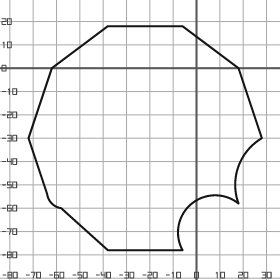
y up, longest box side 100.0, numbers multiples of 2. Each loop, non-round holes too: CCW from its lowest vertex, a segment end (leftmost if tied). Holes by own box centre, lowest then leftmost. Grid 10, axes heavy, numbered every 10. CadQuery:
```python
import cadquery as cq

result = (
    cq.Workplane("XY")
    .moveTo(-38.0, -78.0)
    .lineTo(-6.0, -78.0)
    .threePointArc((-2.0, -58.0), (18.0, -58.0))
    .threePointArc((18.0, -42.0), (28.0, -30.0))
    .lineTo(18.0, 0.0)
    .lineTo(-6.0, 18.0)
    .lineTo(-38.0, 18.0)
    .lineTo(-62.0, 0.0)
    .lineTo(-72.0, -30.0)
    .lineTo(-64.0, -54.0)
    .threePointArc((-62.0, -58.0), (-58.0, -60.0))
    .close()
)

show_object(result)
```